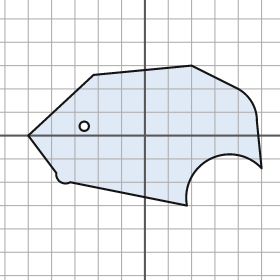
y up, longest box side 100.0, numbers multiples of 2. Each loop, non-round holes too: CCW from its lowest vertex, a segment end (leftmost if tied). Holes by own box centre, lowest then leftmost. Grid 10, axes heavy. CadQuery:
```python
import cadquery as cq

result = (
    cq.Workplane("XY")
    .moveTo(18.0, -30.0)
    .threePointArc((28.0, -10.0), (50.0, -14.0))
    .lineTo(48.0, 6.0)
    .threePointArc((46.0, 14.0), (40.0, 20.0))
    .lineTo(20.0, 30.0)
    .lineTo(-22.0, 26.0)
    .lineTo(-50.0, 0.0)
    .lineTo(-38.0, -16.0)
    .threePointArc((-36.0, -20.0), (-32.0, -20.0))
    .close()
    .moveTo(-26.0, 4.0)
    .circle(2.0)
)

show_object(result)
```